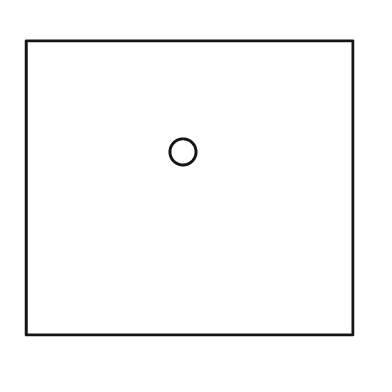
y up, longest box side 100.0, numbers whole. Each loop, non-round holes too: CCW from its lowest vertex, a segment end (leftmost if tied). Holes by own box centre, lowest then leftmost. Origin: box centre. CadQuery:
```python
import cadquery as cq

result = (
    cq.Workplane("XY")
    .moveTo(-50.0, -45.0)
    .lineTo(50.0, -45.0)
    .lineTo(50.0, 45.0)
    .lineTo(-50.0, 45.0)
    .close()
    .moveTo(-2.0, 11.0)
    .circle(4.0)
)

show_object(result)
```